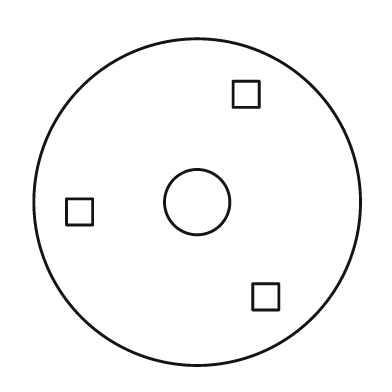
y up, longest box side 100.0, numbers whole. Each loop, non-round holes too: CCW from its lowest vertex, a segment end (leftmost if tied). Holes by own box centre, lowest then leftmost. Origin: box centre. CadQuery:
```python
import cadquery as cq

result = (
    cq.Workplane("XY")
    .moveTo(0.0, 0.0)
    .circle(50.0)
    .moveTo(17.0, -33.0)
    .lineTo(25.0, -33.0)
    .lineTo(25.0, -25.0)
    .lineTo(17.0, -25.0)
    .close()
    .moveTo(-40.0, -7.0)
    .lineTo(-32.0, -7.0)
    .lineTo(-32.0, 1.0)
    .lineTo(-40.0, 1.0)
    .close()
    .moveTo(0.0, 0.0)
    .circle(10.0)
    .moveTo(11.0, 29.0)
    .lineTo(19.0, 29.0)
    .lineTo(19.0, 37.0)
    .lineTo(11.0, 37.0)
    .close()
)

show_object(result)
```